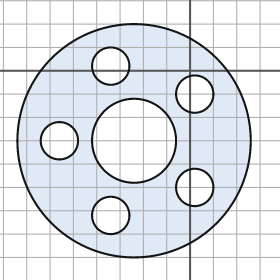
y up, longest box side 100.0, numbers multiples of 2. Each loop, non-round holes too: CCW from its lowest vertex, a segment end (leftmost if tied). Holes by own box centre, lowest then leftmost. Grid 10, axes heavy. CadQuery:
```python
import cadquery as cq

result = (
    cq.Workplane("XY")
    .moveTo(-24.0, -30.0)
    .circle(50.0)
    .moveTo(-34.0, -62.0)
    .circle(8.0)
    .moveTo(2.0, -50.0)
    .circle(8.0)
    .moveTo(-56.0, -30.0)
    .circle(8.0)
    .moveTo(-24.0, -30.0)
    .circle(18.0)
    .moveTo(2.0, -10.0)
    .circle(8.0)
    .moveTo(-34.0, 2.0)
    .circle(8.0)
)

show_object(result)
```